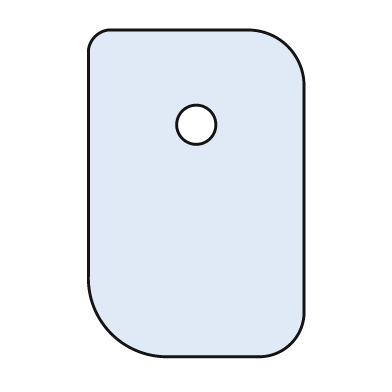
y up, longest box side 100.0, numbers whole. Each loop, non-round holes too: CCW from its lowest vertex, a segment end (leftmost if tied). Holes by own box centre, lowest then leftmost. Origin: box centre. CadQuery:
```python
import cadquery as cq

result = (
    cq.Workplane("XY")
    .moveTo(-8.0, -50.0)
    .lineTo(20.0, -50.0)
    .threePointArc((29.0, -46.0), (33.0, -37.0))
    .lineTo(33.0, 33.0)
    .threePointArc((28.0, 45.0), (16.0, 50.0))
    .lineTo(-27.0, 50.0)
    .threePointArc((-31.0, 48.0), (-33.0, 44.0))
    .lineTo(-33.0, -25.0)
    .threePointArc((-26.0, -43.0), (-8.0, -50.0))
    .close()
    .moveTo(0.0, 21.0)
    .circle(6.0)
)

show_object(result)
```